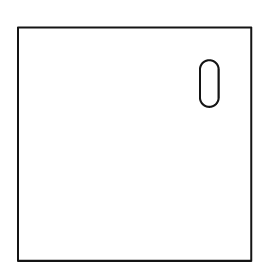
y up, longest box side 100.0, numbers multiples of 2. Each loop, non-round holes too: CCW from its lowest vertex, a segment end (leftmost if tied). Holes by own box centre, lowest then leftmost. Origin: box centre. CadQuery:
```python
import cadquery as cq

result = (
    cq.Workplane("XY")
    .moveTo(-50.0, -50.0)
    .lineTo(50.0, -50.0)
    .lineTo(50.0, 50.0)
    .lineTo(-50.0, 50.0)
    .close()
    .moveTo(28.0, 20.0)
    .threePointArc((32.0, 16.0), (36.0, 20.0))
    .lineTo(36.0, 32.0)
    .threePointArc((32.0, 36.0), (28.0, 32.0))
    .close()
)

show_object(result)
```